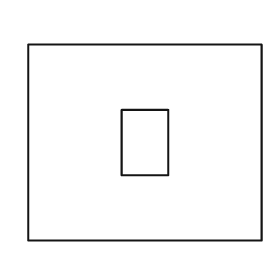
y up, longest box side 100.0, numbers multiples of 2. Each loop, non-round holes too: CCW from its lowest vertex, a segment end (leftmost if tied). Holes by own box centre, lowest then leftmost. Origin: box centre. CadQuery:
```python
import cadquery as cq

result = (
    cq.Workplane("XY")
    .moveTo(-50.0, -42.0)
    .lineTo(50.0, -42.0)
    .lineTo(50.0, 42.0)
    .lineTo(-50.0, 42.0)
    .close()
    .moveTo(-10.0, -14.0)
    .lineTo(10.0, -14.0)
    .lineTo(10.0, 14.0)
    .lineTo(-10.0, 14.0)
    .close()
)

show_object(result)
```